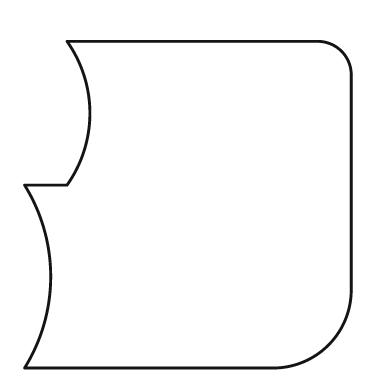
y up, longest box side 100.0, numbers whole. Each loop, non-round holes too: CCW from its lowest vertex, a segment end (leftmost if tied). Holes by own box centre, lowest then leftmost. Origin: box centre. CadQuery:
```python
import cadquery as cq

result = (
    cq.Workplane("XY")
    .moveTo(-50.0, -50.0)
    .lineTo(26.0, -50.0)
    .threePointArc((43.0, -43.0), (50.0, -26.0))
    .lineTo(50.0, 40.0)
    .threePointArc((47.0, 47.0), (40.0, 50.0))
    .lineTo(-37.0, 50.0)
    .threePointArc((-30.0, 28.0), (-37.0, 6.0))
    .lineTo(-50.0, 6.0)
    .threePointArc((-42.0, -22.0), (-50.0, -50.0))
    .close()
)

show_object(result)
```